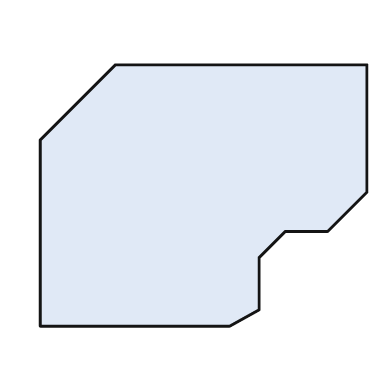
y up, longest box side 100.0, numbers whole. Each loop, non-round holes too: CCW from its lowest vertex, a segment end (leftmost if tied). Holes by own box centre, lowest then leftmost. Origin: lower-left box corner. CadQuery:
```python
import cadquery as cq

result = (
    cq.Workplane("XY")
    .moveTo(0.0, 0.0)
    .lineTo(58.0, 0.0)
    .lineTo(67.0, 5.0)
    .lineTo(67.0, 21.0)
    .lineTo(75.0, 29.0)
    .lineTo(88.0, 29.0)
    .lineTo(100.0, 41.0)
    .lineTo(100.0, 80.0)
    .lineTo(23.0, 80.0)
    .lineTo(0.0, 57.0)
    .close()
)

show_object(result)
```